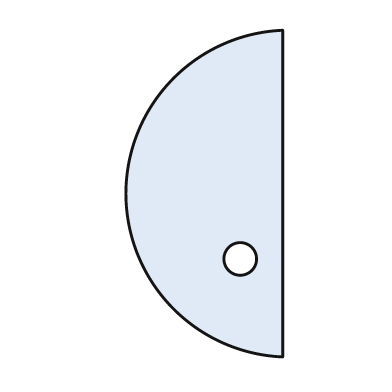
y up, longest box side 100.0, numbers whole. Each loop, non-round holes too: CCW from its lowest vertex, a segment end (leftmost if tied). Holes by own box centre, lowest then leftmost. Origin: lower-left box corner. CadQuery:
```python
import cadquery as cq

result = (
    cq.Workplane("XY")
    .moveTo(48.0, 0.0)
    .lineTo(48.0, 100.0)
    .threePointArc((0.0, 50.0), (48.0, 0.0))
    .close()
    .moveTo(35.0, 30.0)
    .circle(5.0)
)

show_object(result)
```